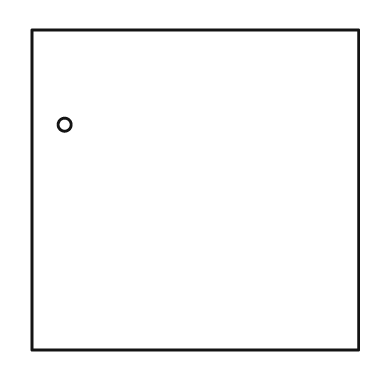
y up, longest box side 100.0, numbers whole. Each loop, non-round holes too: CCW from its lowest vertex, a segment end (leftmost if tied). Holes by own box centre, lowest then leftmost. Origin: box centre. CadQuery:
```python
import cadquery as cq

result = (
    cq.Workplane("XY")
    .moveTo(-50.0, -49.0)
    .lineTo(50.0, -49.0)
    .lineTo(50.0, 49.0)
    .lineTo(-50.0, 49.0)
    .close()
    .moveTo(-40.0, 20.0)
    .circle(2.0)
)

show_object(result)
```